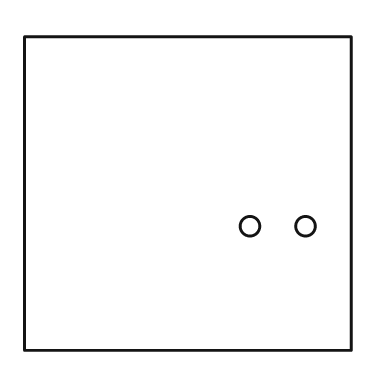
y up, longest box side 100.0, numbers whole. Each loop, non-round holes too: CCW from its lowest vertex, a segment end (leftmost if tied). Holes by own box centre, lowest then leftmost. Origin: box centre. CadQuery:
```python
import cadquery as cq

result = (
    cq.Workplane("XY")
    .moveTo(-50.0, -48.0)
    .lineTo(50.0, -48.0)
    .lineTo(50.0, 48.0)
    .lineTo(-50.0, 48.0)
    .close()
    .moveTo(19.0, -10.0)
    .circle(3.0)
    .moveTo(36.0, -10.0)
    .circle(3.0)
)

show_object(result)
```